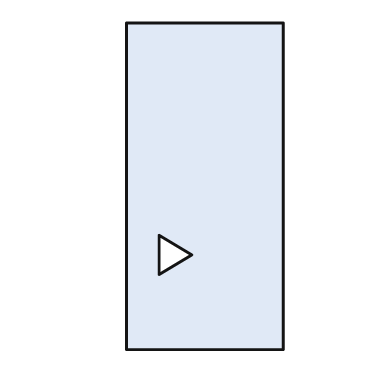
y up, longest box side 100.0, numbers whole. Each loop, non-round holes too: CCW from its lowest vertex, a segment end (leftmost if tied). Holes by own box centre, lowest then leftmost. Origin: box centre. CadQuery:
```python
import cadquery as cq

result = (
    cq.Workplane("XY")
    .moveTo(-24.0, -50.0)
    .lineTo(24.0, -50.0)
    .lineTo(24.0, 50.0)
    .lineTo(-24.0, 50.0)
    .close()
    .moveTo(-14.0, -27.0)
    .lineTo(-4.0, -21.0)
    .lineTo(-14.0, -15.0)
    .close()
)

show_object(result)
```